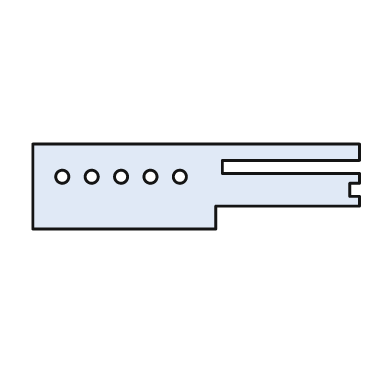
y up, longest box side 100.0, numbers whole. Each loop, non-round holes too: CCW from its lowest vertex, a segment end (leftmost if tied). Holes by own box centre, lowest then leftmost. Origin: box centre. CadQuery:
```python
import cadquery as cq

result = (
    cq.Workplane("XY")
    .moveTo(-50.0, -13.0)
    .lineTo(6.0, -13.0)
    .lineTo(6.0, -6.0)
    .lineTo(50.0, -6.0)
    .lineTo(50.0, -3.0)
    .lineTo(47.0, -3.0)
    .lineTo(47.0, 1.0)
    .lineTo(50.0, 1.0)
    .lineTo(50.0, 4.0)
    .lineTo(8.0, 4.0)
    .lineTo(8.0, 8.0)
    .lineTo(50.0, 8.0)
    .lineTo(50.0, 13.0)
    .lineTo(-50.0, 13.0)
    .close()
    .moveTo(-41.0, 3.0)
    .circle(2.0)
    .moveTo(-32.0, 3.0)
    .circle(2.0)
    .moveTo(-23.0, 3.0)
    .circle(2.0)
    .moveTo(-14.0, 3.0)
    .circle(2.0)
    .moveTo(-5.0, 3.0)
    .circle(2.0)
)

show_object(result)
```